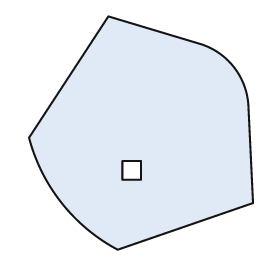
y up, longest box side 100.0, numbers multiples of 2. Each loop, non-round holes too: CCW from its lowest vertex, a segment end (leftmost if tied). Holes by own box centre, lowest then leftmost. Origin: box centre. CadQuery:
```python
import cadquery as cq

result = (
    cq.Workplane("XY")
    .moveTo(-10.0, -50.0)
    .lineTo(48.0, -30.0)
    .lineTo(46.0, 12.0)
    .threePointArc((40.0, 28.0), (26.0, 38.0))
    .lineTo(-14.0, 50.0)
    .lineTo(-48.0, -2.0)
    .threePointArc((-34.0, -30.0), (-10.0, -50.0))
    .close()
    .moveTo(-8.0, -20.0)
    .lineTo(0.0, -20.0)
    .lineTo(0.0, -12.0)
    .lineTo(-8.0, -12.0)
    .close()
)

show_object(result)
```